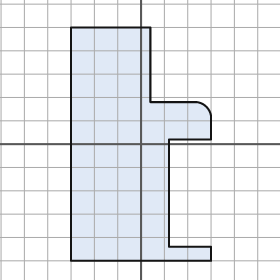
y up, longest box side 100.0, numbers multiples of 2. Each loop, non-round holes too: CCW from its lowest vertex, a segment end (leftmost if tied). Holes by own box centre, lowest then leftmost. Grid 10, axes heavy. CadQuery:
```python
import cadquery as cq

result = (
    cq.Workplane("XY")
    .moveTo(-30.0, -50.0)
    .lineTo(30.0, -50.0)
    .lineTo(30.0, -44.0)
    .lineTo(12.0, -44.0)
    .lineTo(12.0, 2.0)
    .lineTo(30.0, 2.0)
    .lineTo(30.0, 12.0)
    .threePointArc((28.0, 16.0), (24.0, 18.0))
    .lineTo(4.0, 18.0)
    .lineTo(4.0, 50.0)
    .lineTo(-30.0, 50.0)
    .close()
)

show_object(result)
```